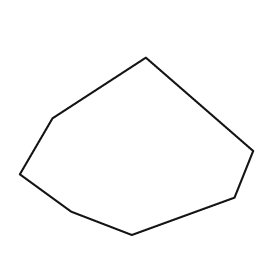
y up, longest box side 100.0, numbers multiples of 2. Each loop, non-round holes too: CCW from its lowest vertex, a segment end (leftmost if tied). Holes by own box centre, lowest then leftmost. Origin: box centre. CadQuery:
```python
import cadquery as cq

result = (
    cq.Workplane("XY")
    .moveTo(-2.0, -38.0)
    .lineTo(42.0, -22.0)
    .lineTo(50.0, -2.0)
    .lineTo(4.0, 38.0)
    .lineTo(-36.0, 12.0)
    .lineTo(-50.0, -12.0)
    .lineTo(-28.0, -28.0)
    .close()
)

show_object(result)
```